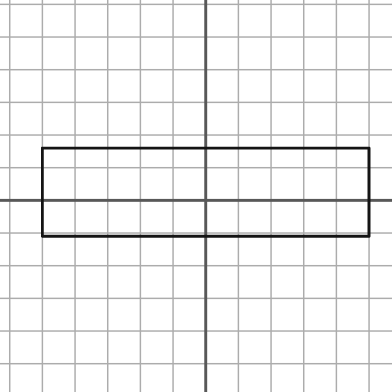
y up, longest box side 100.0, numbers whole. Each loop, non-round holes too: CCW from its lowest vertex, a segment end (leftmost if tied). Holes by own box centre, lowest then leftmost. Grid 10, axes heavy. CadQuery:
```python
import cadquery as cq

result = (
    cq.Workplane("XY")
    .moveTo(-50.0, -11.0)
    .lineTo(50.0, -11.0)
    .lineTo(50.0, 16.0)
    .lineTo(-50.0, 16.0)
    .close()
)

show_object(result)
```